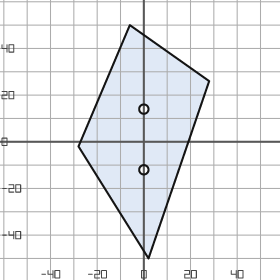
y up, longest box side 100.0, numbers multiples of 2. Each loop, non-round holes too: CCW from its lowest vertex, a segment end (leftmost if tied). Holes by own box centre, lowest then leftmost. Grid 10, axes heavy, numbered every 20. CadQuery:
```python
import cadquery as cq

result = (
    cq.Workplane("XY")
    .moveTo(2.0, -50.0)
    .lineTo(28.0, 26.0)
    .lineTo(-6.0, 50.0)
    .lineTo(-28.0, -2.0)
    .close()
    .moveTo(0.0, -12.0)
    .circle(2.0)
    .moveTo(0.0, 14.0)
    .circle(2.0)
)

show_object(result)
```